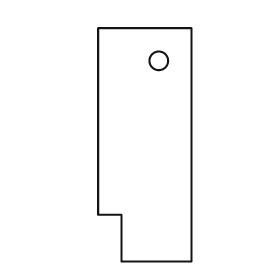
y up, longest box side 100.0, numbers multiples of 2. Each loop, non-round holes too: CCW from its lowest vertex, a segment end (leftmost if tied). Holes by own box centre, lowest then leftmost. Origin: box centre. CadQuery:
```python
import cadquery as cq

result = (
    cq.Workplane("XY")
    .moveTo(-10.0, -50.0)
    .lineTo(20.0, -50.0)
    .lineTo(20.0, 50.0)
    .lineTo(-20.0, 50.0)
    .lineTo(-20.0, -30.0)
    .lineTo(-10.0, -30.0)
    .close()
    .moveTo(6.0, 36.0)
    .circle(4.0)
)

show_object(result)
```